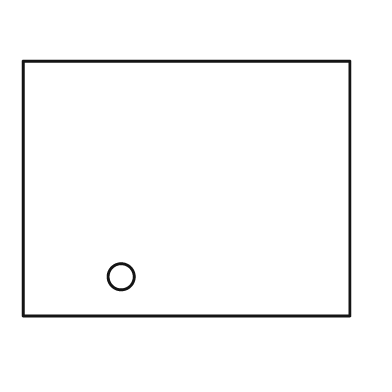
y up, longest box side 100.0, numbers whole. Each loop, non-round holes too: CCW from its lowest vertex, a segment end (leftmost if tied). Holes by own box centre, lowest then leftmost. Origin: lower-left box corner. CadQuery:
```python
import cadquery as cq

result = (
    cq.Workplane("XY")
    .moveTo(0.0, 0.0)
    .lineTo(100.0, 0.0)
    .lineTo(100.0, 78.0)
    .lineTo(0.0, 78.0)
    .close()
    .moveTo(30.0, 12.0)
    .circle(4.0)
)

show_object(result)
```